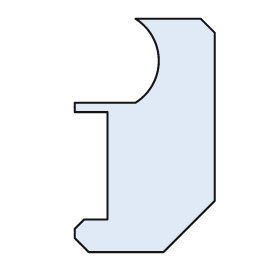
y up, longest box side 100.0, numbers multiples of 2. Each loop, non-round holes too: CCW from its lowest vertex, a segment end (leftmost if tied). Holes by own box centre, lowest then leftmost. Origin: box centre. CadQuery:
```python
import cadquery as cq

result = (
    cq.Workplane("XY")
    .moveTo(-24.0, -50.0)
    .lineTo(8.0, -50.0)
    .lineTo(30.0, -28.0)
    .lineTo(30.0, 44.0)
    .lineTo(24.0, 50.0)
    .lineTo(-4.0, 50.0)
    .threePointArc((6.0, 32.0), (-4.0, 14.0))
    .lineTo(-30.0, 14.0)
    .lineTo(-30.0, 10.0)
    .lineTo(-16.0, 10.0)
    .lineTo(-16.0, -36.0)
    .lineTo(-26.0, -36.0)
    .lineTo(-30.0, -40.0)
    .lineTo(-30.0, -44.0)
    .close()
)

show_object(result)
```